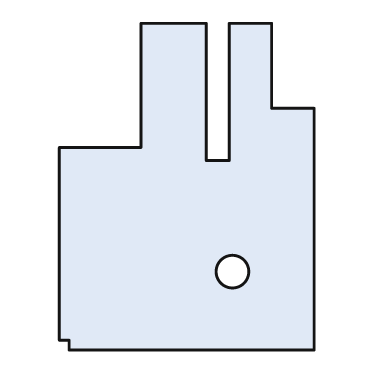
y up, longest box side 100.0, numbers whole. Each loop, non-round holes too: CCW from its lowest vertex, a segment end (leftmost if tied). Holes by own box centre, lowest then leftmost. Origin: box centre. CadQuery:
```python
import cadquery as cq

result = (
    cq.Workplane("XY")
    .moveTo(-36.0, -50.0)
    .lineTo(39.0, -50.0)
    .lineTo(39.0, 24.0)
    .lineTo(26.0, 24.0)
    .lineTo(26.0, 50.0)
    .lineTo(13.0, 50.0)
    .lineTo(13.0, 8.0)
    .lineTo(6.0, 8.0)
    .lineTo(6.0, 50.0)
    .lineTo(-14.0, 50.0)
    .lineTo(-14.0, 12.0)
    .lineTo(-39.0, 12.0)
    .lineTo(-39.0, -47.0)
    .lineTo(-36.0, -47.0)
    .close()
    .moveTo(14.0, -26.0)
    .circle(5.0)
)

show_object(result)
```